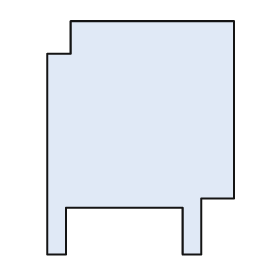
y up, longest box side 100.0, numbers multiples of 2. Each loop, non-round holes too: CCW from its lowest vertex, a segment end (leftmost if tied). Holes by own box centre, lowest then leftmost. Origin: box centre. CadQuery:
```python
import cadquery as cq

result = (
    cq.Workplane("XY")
    .moveTo(-40.0, -50.0)
    .lineTo(-32.0, -50.0)
    .lineTo(-32.0, -30.0)
    .lineTo(18.0, -30.0)
    .lineTo(18.0, -50.0)
    .lineTo(26.0, -50.0)
    .lineTo(26.0, -26.0)
    .lineTo(40.0, -26.0)
    .lineTo(40.0, 50.0)
    .lineTo(-30.0, 50.0)
    .lineTo(-30.0, 36.0)
    .lineTo(-40.0, 36.0)
    .close()
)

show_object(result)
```